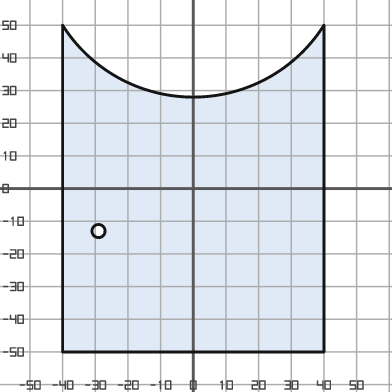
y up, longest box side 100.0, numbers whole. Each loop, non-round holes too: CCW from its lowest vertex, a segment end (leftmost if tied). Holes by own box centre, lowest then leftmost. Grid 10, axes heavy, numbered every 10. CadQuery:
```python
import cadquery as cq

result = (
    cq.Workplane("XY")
    .moveTo(-40.0, -50.0)
    .lineTo(40.0, -50.0)
    .lineTo(40.0, 50.0)
    .threePointArc((0.0, 28.0), (-40.0, 50.0))
    .close()
    .moveTo(-29.0, -13.0)
    .circle(2.0)
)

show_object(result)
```